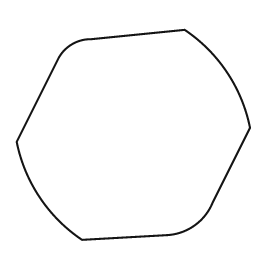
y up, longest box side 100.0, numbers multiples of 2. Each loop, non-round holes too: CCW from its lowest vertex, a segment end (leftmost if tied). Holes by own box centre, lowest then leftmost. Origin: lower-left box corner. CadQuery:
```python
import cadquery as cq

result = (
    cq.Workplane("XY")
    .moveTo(28.0, 0.0)
    .lineTo(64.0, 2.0)
    .threePointArc((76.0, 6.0), (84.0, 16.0))
    .lineTo(100.0, 48.0)
    .threePointArc((90.0, 72.0), (72.0, 90.0))
    .lineTo(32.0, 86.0)
    .threePointArc((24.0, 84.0), (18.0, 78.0))
    .lineTo(0.0, 42.0)
    .threePointArc((10.0, 18.0), (28.0, 0.0))
    .close()
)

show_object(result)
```